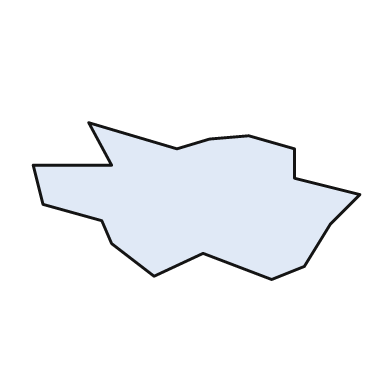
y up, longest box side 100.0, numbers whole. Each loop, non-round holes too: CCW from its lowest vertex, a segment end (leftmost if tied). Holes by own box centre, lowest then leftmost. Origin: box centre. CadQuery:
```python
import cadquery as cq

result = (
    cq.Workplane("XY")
    .moveTo(23.0, -24.0)
    .lineTo(33.0, -20.0)
    .lineTo(41.0, -7.0)
    .lineTo(50.0, 2.0)
    .lineTo(30.0, 7.0)
    .lineTo(30.0, 16.0)
    .lineTo(16.0, 20.0)
    .lineTo(4.0, 19.0)
    .lineTo(-6.0, 16.0)
    .lineTo(-33.0, 24.0)
    .lineTo(-26.0, 11.0)
    .lineTo(-50.0, 11.0)
    .lineTo(-47.0, -1.0)
    .lineTo(-29.0, -6.0)
    .lineTo(-26.0, -13.0)
    .lineTo(-13.0, -23.0)
    .lineTo(2.0, -16.0)
    .close()
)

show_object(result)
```